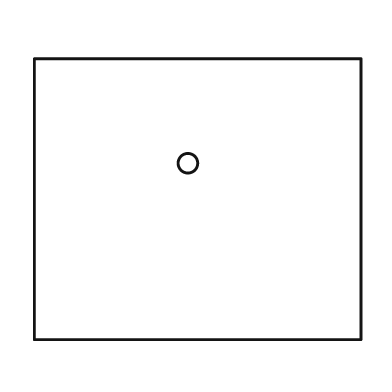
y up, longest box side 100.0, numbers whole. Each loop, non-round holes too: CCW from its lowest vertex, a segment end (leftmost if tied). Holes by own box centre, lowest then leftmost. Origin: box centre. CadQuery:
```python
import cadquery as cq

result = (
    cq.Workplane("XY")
    .moveTo(-50.0, -43.0)
    .lineTo(50.0, -43.0)
    .lineTo(50.0, 43.0)
    .lineTo(-50.0, 43.0)
    .close()
    .moveTo(-3.0, 11.0)
    .circle(3.0)
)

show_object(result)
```